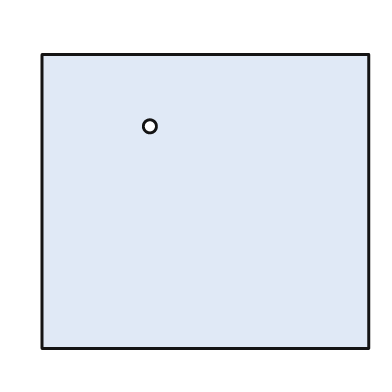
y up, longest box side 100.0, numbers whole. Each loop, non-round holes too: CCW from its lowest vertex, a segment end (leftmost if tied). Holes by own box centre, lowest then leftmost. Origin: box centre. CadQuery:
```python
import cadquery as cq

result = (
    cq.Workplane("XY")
    .moveTo(-50.0, -45.0)
    .lineTo(50.0, -45.0)
    .lineTo(50.0, 45.0)
    .lineTo(-50.0, 45.0)
    .close()
    .moveTo(-17.0, 23.0)
    .circle(2.0)
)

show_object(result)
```